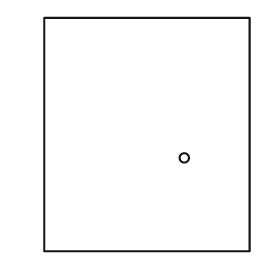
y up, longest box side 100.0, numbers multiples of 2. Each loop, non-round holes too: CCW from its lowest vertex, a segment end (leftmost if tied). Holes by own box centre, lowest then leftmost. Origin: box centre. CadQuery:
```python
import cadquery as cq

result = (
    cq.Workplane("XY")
    .moveTo(-44.0, -50.0)
    .lineTo(44.0, -50.0)
    .lineTo(44.0, 50.0)
    .lineTo(-44.0, 50.0)
    .close()
    .moveTo(16.0, -10.0)
    .circle(2.0)
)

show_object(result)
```